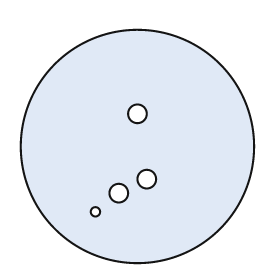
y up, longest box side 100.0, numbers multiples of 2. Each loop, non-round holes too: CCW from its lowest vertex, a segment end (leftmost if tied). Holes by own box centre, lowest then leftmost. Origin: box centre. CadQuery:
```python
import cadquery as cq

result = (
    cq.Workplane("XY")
    .moveTo(0.0, 0.0)
    .circle(50.0)
    .moveTo(-18.0, -28.0)
    .circle(2.0)
    .moveTo(-8.0, -20.0)
    .circle(4.0)
    .moveTo(4.0, -14.0)
    .circle(4.0)
    .moveTo(0.0, 14.0)
    .circle(4.0)
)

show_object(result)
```